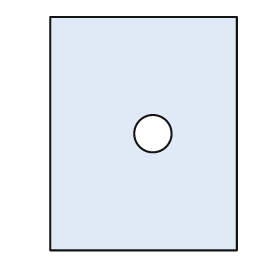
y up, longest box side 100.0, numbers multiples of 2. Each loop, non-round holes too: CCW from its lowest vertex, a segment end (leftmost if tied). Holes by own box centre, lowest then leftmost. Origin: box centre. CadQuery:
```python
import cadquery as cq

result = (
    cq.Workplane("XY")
    .moveTo(-40.0, -50.0)
    .lineTo(40.0, -50.0)
    .lineTo(40.0, 50.0)
    .lineTo(-40.0, 50.0)
    .close()
    .moveTo(4.0, 0.0)
    .circle(8.0)
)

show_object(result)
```